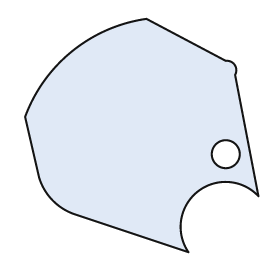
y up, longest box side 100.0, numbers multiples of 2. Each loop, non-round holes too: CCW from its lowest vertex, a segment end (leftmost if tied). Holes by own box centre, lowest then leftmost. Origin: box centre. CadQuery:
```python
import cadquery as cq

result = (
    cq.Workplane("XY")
    .moveTo(20.0, -50.0)
    .threePointArc((24.0, -24.0), (50.0, -26.0))
    .lineTo(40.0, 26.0)
    .threePointArc((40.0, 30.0), (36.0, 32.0))
    .lineTo(2.0, 50.0)
    .threePointArc((-30.0, 36.0), (-50.0, 8.0))
    .lineTo(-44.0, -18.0)
    .threePointArc((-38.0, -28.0), (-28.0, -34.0))
    .close()
    .moveTo(36.0, -8.0)
    .circle(6.0)
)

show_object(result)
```